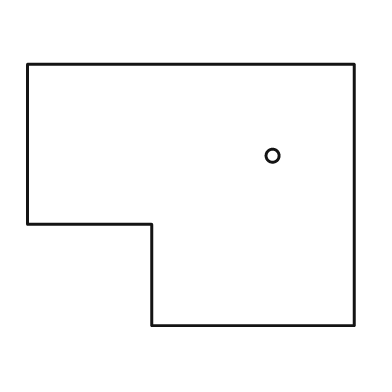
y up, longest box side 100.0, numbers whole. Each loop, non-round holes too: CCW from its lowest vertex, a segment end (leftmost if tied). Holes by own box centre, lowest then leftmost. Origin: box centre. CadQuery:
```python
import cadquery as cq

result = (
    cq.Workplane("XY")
    .moveTo(-12.0, -40.0)
    .lineTo(50.0, -40.0)
    .lineTo(50.0, 40.0)
    .lineTo(-50.0, 40.0)
    .lineTo(-50.0, -9.0)
    .lineTo(-12.0, -9.0)
    .close()
    .moveTo(25.0, 12.0)
    .circle(2.0)
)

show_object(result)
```